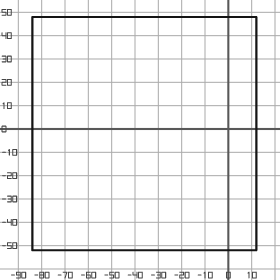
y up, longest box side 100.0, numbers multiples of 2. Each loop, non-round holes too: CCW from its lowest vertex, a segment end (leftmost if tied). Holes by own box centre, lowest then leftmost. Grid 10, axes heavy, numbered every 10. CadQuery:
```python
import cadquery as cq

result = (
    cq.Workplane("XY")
    .moveTo(-84.0, -52.0)
    .lineTo(12.0, -52.0)
    .lineTo(12.0, 48.0)
    .lineTo(-84.0, 48.0)
    .close()
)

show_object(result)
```